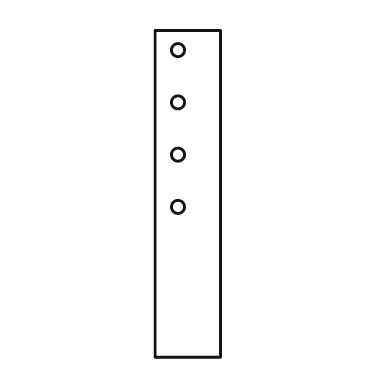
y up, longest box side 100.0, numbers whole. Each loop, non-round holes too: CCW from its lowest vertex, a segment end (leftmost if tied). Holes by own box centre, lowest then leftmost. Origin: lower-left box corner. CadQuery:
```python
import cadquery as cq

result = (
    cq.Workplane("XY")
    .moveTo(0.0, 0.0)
    .lineTo(20.0, 0.0)
    .lineTo(20.0, 100.0)
    .lineTo(0.0, 100.0)
    .close()
    .moveTo(7.0, 46.0)
    .circle(2.0)
    .moveTo(7.0, 62.0)
    .circle(2.0)
    .moveTo(7.0, 78.0)
    .circle(2.0)
    .moveTo(7.0, 94.0)
    .circle(2.0)
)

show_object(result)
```